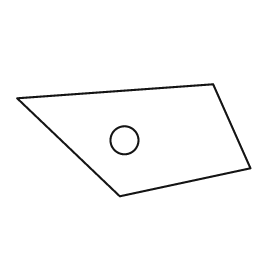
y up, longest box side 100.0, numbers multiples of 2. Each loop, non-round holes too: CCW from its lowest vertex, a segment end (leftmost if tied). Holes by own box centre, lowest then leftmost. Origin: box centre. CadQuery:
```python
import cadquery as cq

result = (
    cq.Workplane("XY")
    .moveTo(-6.0, -24.0)
    .lineTo(50.0, -12.0)
    .lineTo(34.0, 24.0)
    .lineTo(-50.0, 18.0)
    .close()
    .moveTo(-4.0, 0.0)
    .circle(6.0)
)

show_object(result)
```